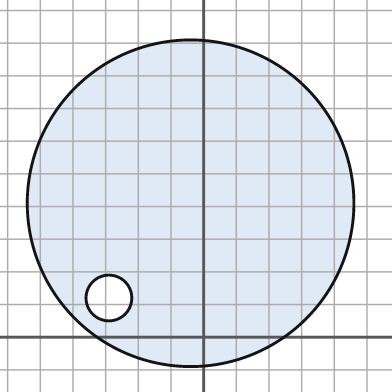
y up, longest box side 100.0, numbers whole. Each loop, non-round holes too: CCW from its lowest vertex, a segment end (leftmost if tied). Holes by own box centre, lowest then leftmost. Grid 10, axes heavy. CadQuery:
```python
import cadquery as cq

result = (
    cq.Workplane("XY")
    .moveTo(-4.0, 41.0)
    .circle(50.0)
    .moveTo(-29.0, 12.0)
    .circle(7.0)
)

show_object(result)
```